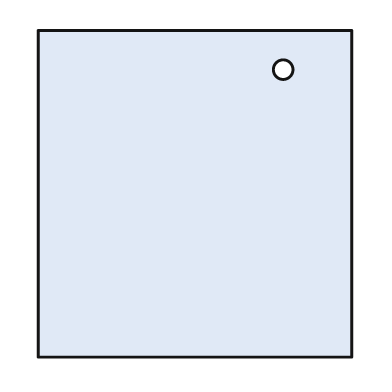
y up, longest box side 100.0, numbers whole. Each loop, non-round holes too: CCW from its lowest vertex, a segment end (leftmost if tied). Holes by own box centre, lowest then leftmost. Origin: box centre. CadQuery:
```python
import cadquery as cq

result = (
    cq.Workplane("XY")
    .moveTo(-48.0, -50.0)
    .lineTo(48.0, -50.0)
    .lineTo(48.0, 50.0)
    .lineTo(-48.0, 50.0)
    .close()
    .moveTo(27.0, 38.0)
    .circle(3.0)
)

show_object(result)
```